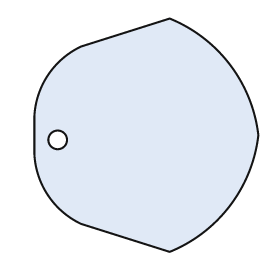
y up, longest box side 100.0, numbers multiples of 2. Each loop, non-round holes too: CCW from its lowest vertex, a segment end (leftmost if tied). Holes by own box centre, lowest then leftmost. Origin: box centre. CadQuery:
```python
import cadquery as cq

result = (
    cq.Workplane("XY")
    .moveTo(10.0, -50.0)
    .threePointArc((36.0, -30.0), (48.0, 0.0))
    .threePointArc((36.0, 30.0), (10.0, 50.0))
    .lineTo(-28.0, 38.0)
    .threePointArc((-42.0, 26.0), (-48.0, 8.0))
    .lineTo(-48.0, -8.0)
    .threePointArc((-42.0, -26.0), (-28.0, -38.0))
    .close()
    .moveTo(-38.0, -2.0)
    .circle(4.0)
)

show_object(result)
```